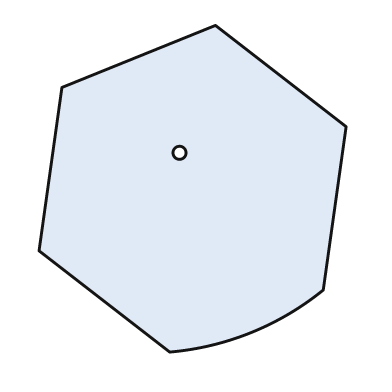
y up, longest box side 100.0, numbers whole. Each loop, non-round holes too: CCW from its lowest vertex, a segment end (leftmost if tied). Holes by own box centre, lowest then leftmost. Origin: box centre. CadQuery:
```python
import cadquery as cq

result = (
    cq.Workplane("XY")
    .moveTo(-7.0, -50.0)
    .threePointArc((18.0, -44.0), (40.0, -31.0))
    .lineTo(47.0, 19.0)
    .lineTo(7.0, 50.0)
    .lineTo(-40.0, 31.0)
    .lineTo(-47.0, -19.0)
    .close()
    .moveTo(-4.0, 11.0)
    .circle(2.0)
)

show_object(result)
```